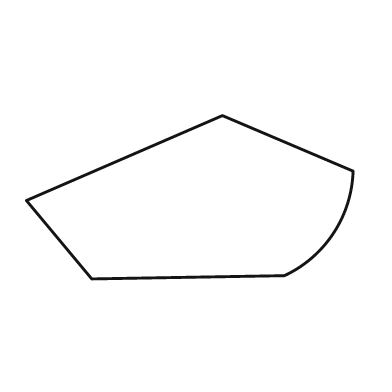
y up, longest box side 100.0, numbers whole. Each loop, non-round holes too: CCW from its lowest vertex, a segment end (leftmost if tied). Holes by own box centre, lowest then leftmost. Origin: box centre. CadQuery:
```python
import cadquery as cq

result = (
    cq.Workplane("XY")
    .moveTo(-30.0, -25.0)
    .lineTo(29.0, -24.0)
    .threePointArc((44.0, -11.0), (50.0, 8.0))
    .lineTo(10.0, 25.0)
    .lineTo(-50.0, -1.0)
    .close()
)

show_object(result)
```